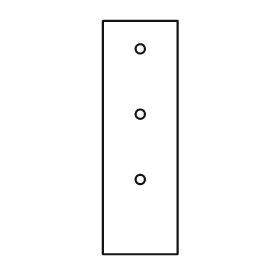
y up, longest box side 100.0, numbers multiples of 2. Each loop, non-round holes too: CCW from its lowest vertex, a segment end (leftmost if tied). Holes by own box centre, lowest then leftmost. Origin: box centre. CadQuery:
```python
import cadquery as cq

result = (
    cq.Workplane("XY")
    .moveTo(-16.0, -50.0)
    .lineTo(16.0, -50.0)
    .lineTo(16.0, 50.0)
    .lineTo(-16.0, 50.0)
    .close()
    .moveTo(0.0, -18.0)
    .circle(2.0)
    .moveTo(0.0, 10.0)
    .circle(2.0)
    .moveTo(0.0, 38.0)
    .circle(2.0)
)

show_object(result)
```